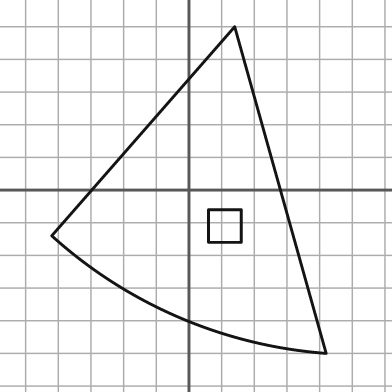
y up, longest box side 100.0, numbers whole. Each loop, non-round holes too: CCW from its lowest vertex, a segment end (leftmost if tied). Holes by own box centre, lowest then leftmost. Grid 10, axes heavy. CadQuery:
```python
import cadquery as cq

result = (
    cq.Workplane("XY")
    .moveTo(42.0, -50.0)
    .lineTo(14.0, 50.0)
    .lineTo(-42.0, -14.0)
    .threePointArc((-3.0, -39.0), (42.0, -50.0))
    .close()
    .moveTo(6.0, -16.0)
    .lineTo(16.0, -16.0)
    .lineTo(16.0, -6.0)
    .lineTo(6.0, -6.0)
    .close()
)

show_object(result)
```